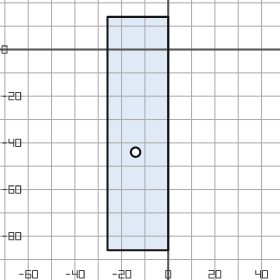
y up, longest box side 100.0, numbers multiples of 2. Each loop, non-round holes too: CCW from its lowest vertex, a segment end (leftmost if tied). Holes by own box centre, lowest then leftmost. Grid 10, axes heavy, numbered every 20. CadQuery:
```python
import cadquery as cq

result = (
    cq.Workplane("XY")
    .moveTo(-26.0, -86.0)
    .lineTo(0.0, -86.0)
    .lineTo(0.0, 14.0)
    .lineTo(-26.0, 14.0)
    .close()
    .moveTo(-14.0, -44.0)
    .circle(2.0)
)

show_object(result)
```